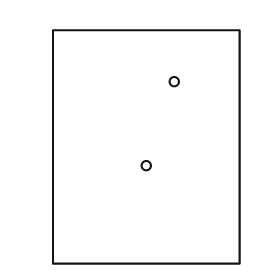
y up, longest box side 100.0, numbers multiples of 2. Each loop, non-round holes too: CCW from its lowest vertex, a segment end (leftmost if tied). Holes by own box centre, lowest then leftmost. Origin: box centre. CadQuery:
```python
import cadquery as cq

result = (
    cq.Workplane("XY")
    .moveTo(-40.0, -50.0)
    .lineTo(40.0, -50.0)
    .lineTo(40.0, 50.0)
    .lineTo(-40.0, 50.0)
    .close()
    .moveTo(0.0, -8.0)
    .circle(2.0)
    .moveTo(12.0, 28.0)
    .circle(2.0)
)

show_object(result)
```